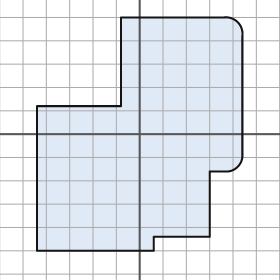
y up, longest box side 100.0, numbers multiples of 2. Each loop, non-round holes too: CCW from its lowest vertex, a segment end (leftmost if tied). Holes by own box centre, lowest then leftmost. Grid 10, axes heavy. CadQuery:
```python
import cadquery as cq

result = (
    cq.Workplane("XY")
    .moveTo(-44.0, -50.0)
    .lineTo(6.0, -50.0)
    .lineTo(6.0, -44.0)
    .lineTo(30.0, -44.0)
    .lineTo(30.0, -16.0)
    .lineTo(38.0, -16.0)
    .threePointArc((42.0, -14.0), (44.0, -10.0))
    .lineTo(44.0, 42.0)
    .threePointArc((42.0, 48.0), (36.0, 50.0))
    .lineTo(-8.0, 50.0)
    .lineTo(-8.0, 12.0)
    .lineTo(-44.0, 12.0)
    .close()
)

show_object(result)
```